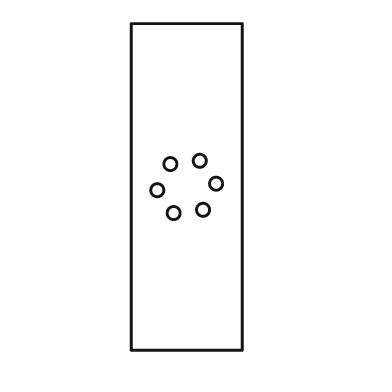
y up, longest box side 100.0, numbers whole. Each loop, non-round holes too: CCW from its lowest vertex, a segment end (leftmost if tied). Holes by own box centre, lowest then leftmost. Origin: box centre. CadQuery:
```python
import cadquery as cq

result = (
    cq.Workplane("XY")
    .moveTo(-17.0, -50.0)
    .lineTo(17.0, -50.0)
    .lineTo(17.0, 50.0)
    .lineTo(-17.0, 50.0)
    .close()
    .moveTo(-4.0, -8.0)
    .circle(2.0)
    .moveTo(5.0, -7.0)
    .circle(2.0)
    .moveTo(-9.0, -1.0)
    .circle(2.0)
    .moveTo(9.0, 1.0)
    .circle(2.0)
    .moveTo(-5.0, 7.0)
    .circle(2.0)
    .moveTo(4.0, 8.0)
    .circle(2.0)
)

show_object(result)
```